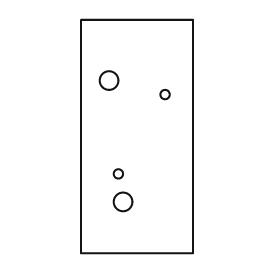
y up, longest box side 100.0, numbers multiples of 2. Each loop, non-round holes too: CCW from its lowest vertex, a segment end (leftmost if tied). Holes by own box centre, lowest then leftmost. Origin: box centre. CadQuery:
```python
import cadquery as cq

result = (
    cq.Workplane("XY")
    .moveTo(-24.0, -50.0)
    .lineTo(24.0, -50.0)
    .lineTo(24.0, 50.0)
    .lineTo(-24.0, 50.0)
    .close()
    .moveTo(-6.0, -28.0)
    .circle(4.0)
    .moveTo(-8.0, -16.0)
    .circle(2.0)
    .moveTo(12.0, 18.0)
    .circle(2.0)
    .moveTo(-12.0, 24.0)
    .circle(4.0)
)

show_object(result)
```